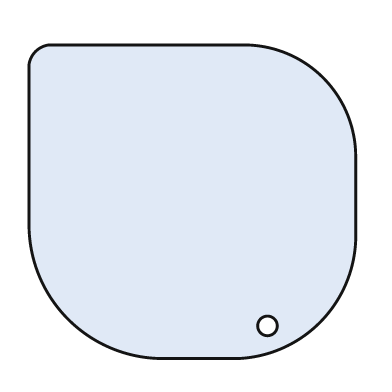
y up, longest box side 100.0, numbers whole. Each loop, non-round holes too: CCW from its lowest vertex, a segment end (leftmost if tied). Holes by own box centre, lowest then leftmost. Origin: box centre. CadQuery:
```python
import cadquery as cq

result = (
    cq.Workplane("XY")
    .moveTo(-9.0, -48.0)
    .lineTo(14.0, -48.0)
    .threePointArc((39.0, -37.0), (50.0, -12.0))
    .lineTo(50.0, 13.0)
    .threePointArc((40.0, 38.0), (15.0, 48.0))
    .lineTo(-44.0, 48.0)
    .threePointArc((-48.0, 46.0), (-50.0, 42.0))
    .lineTo(-50.0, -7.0)
    .threePointArc((-38.0, -36.0), (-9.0, -48.0))
    .close()
    .moveTo(23.0, -38.0)
    .circle(3.0)
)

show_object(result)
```